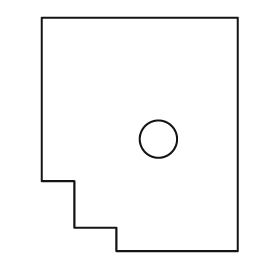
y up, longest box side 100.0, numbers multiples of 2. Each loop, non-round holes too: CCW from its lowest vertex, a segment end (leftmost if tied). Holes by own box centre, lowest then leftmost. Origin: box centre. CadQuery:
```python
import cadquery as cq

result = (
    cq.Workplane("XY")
    .moveTo(-10.0, -50.0)
    .lineTo(42.0, -50.0)
    .lineTo(42.0, 50.0)
    .lineTo(-42.0, 50.0)
    .lineTo(-42.0, -20.0)
    .lineTo(-28.0, -20.0)
    .lineTo(-28.0, -40.0)
    .lineTo(-10.0, -40.0)
    .close()
    .moveTo(8.0, -2.0)
    .circle(8.0)
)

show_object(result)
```